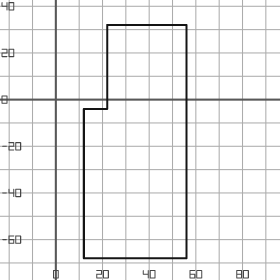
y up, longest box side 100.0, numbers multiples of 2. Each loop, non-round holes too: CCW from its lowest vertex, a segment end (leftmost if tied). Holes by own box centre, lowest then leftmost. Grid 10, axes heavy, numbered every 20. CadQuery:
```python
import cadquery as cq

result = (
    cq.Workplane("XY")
    .moveTo(12.0, -68.0)
    .lineTo(56.0, -68.0)
    .lineTo(56.0, 32.0)
    .lineTo(22.0, 32.0)
    .lineTo(22.0, -4.0)
    .lineTo(12.0, -4.0)
    .close()
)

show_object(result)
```